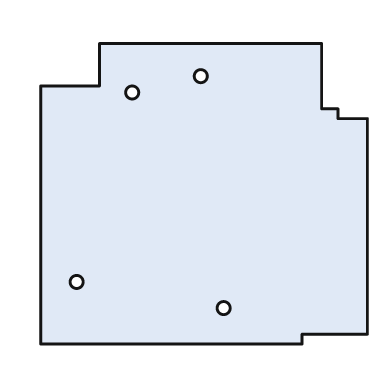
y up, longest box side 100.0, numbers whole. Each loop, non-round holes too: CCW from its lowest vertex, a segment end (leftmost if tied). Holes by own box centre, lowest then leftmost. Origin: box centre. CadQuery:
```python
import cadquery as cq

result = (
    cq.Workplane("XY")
    .moveTo(-50.0, -46.0)
    .lineTo(30.0, -46.0)
    .lineTo(30.0, -43.0)
    .lineTo(50.0, -43.0)
    .lineTo(50.0, 23.0)
    .lineTo(41.0, 23.0)
    .lineTo(41.0, 26.0)
    .lineTo(36.0, 26.0)
    .lineTo(36.0, 46.0)
    .lineTo(-32.0, 46.0)
    .lineTo(-32.0, 33.0)
    .lineTo(-50.0, 33.0)
    .close()
    .moveTo(6.0, -35.0)
    .circle(2.0)
    .moveTo(-39.0, -27.0)
    .circle(2.0)
    .moveTo(-22.0, 31.0)
    .circle(2.0)
    .moveTo(-1.0, 36.0)
    .circle(2.0)
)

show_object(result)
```